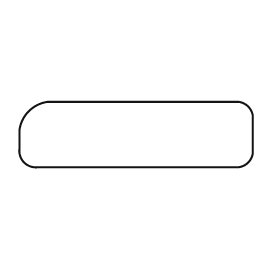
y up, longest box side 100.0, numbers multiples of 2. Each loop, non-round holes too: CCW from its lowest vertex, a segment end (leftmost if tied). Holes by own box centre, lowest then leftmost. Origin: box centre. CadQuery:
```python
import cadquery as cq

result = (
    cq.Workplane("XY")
    .moveTo(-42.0, -14.0)
    .lineTo(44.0, -14.0)
    .threePointArc((48.0, -12.0), (50.0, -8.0))
    .lineTo(50.0, 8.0)
    .threePointArc((48.0, 12.0), (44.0, 14.0))
    .lineTo(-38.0, 14.0)
    .threePointArc((-46.0, 10.0), (-50.0, 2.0))
    .lineTo(-50.0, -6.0)
    .threePointArc((-48.0, -12.0), (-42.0, -14.0))
    .close()
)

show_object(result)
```